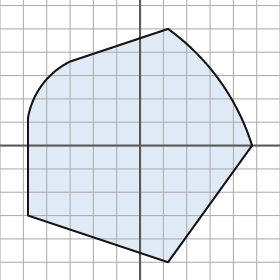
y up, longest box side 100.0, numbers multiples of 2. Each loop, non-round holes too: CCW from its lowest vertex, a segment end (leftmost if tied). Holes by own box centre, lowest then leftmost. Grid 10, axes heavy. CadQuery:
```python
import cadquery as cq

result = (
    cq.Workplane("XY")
    .moveTo(12.0, -50.0)
    .lineTo(48.0, 0.0)
    .threePointArc((34.0, 28.0), (12.0, 50.0))
    .lineTo(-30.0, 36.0)
    .threePointArc((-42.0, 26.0), (-48.0, 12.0))
    .lineTo(-48.0, -30.0)
    .close()
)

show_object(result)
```